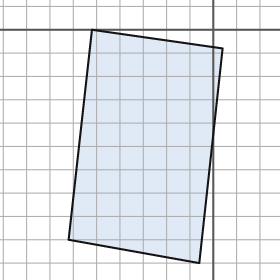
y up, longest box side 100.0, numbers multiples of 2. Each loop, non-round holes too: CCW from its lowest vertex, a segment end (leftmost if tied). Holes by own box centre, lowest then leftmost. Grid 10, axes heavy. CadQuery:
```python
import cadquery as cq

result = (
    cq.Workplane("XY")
    .moveTo(-6.0, -100.0)
    .lineTo(4.0, -8.0)
    .lineTo(-52.0, 0.0)
    .lineTo(-62.0, -90.0)
    .close()
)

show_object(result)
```